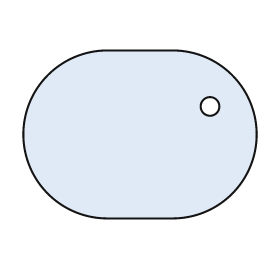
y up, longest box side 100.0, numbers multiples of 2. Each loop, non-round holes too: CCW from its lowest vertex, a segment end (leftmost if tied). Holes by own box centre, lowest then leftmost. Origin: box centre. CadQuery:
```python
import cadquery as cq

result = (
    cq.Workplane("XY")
    .moveTo(-14.0, -36.0)
    .lineTo(14.0, -36.0)
    .threePointArc((50.0, 0.0), (14.0, 36.0))
    .lineTo(-14.0, 36.0)
    .threePointArc((-50.0, 0.0), (-14.0, -36.0))
    .close()
    .moveTo(30.0, 12.0)
    .circle(4.0)
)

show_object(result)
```